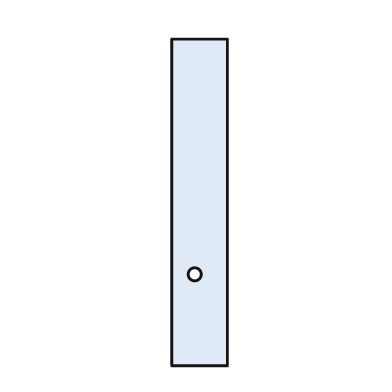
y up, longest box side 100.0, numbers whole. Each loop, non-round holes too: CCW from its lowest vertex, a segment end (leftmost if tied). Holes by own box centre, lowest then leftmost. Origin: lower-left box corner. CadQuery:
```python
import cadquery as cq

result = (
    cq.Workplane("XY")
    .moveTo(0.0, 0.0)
    .lineTo(17.0, 0.0)
    .lineTo(17.0, 100.0)
    .lineTo(0.0, 100.0)
    .close()
    .moveTo(7.0, 28.0)
    .circle(2.0)
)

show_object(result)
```